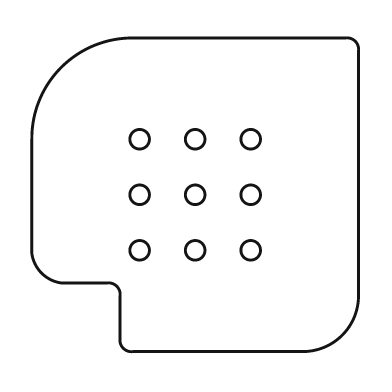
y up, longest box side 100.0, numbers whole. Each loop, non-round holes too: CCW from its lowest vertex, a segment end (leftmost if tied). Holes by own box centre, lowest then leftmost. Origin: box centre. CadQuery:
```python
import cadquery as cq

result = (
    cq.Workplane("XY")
    .moveTo(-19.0, -48.0)
    .lineTo(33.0, -48.0)
    .threePointArc((45.0, -43.0), (50.0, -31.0))
    .lineTo(50.0, 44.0)
    .threePointArc((49.0, 47.0), (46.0, 48.0))
    .lineTo(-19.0, 48.0)
    .threePointArc((-41.0, 39.0), (-50.0, 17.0))
    .lineTo(-50.0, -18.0)
    .threePointArc((-47.0, -24.0), (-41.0, -27.0))
    .lineTo(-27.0, -27.0)
    .threePointArc((-24.0, -28.0), (-23.0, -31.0))
    .lineTo(-23.0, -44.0)
    .threePointArc((-22.0, -47.0), (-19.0, -48.0))
    .close()
    .moveTo(-17.0, -17.0)
    .circle(3.0)
    .moveTo(0.0, -17.0)
    .circle(3.0)
    .moveTo(17.0, -17.0)
    .circle(3.0)
    .moveTo(-17.0, 0.0)
    .circle(3.0)
    .moveTo(0.0, 0.0)
    .circle(3.0)
    .moveTo(17.0, 0.0)
    .circle(3.0)
    .moveTo(-17.0, 17.0)
    .circle(3.0)
    .moveTo(0.0, 17.0)
    .circle(3.0)
    .moveTo(17.0, 17.0)
    .circle(3.0)
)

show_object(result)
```